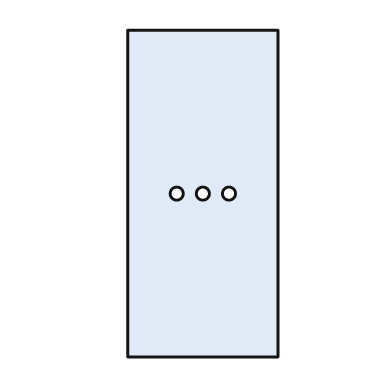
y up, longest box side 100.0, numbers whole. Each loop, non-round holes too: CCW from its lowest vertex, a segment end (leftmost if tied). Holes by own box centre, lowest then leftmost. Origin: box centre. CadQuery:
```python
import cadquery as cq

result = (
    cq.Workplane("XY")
    .moveTo(-23.0, -50.0)
    .lineTo(23.0, -50.0)
    .lineTo(23.0, 50.0)
    .lineTo(-23.0, 50.0)
    .close()
    .moveTo(-8.0, 0.0)
    .circle(2.0)
    .moveTo(0.0, 0.0)
    .circle(2.0)
    .moveTo(8.0, 0.0)
    .circle(2.0)
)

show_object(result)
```